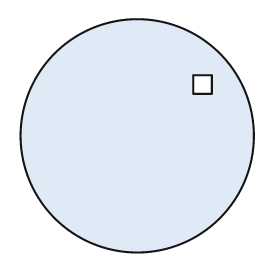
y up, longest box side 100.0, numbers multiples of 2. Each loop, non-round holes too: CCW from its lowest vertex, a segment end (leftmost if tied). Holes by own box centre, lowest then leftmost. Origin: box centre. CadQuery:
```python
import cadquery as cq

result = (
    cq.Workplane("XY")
    .moveTo(0.0, 0.0)
    .circle(50.0)
    .moveTo(24.0, 18.0)
    .lineTo(32.0, 18.0)
    .lineTo(32.0, 26.0)
    .lineTo(24.0, 26.0)
    .close()
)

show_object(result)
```